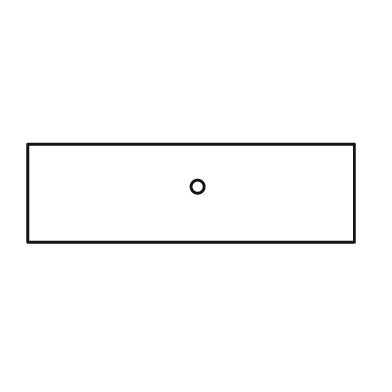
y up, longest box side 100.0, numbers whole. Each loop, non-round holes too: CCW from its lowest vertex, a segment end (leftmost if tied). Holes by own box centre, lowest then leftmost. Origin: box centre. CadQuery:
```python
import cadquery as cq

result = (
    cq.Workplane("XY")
    .moveTo(-50.0, -15.0)
    .lineTo(50.0, -15.0)
    .lineTo(50.0, 15.0)
    .lineTo(-50.0, 15.0)
    .close()
    .moveTo(2.0, 2.0)
    .circle(2.0)
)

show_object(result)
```